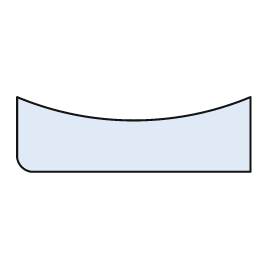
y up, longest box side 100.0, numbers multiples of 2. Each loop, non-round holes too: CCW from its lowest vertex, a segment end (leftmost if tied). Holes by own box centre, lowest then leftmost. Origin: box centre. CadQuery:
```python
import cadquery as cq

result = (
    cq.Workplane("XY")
    .moveTo(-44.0, -16.0)
    .lineTo(50.0, -16.0)
    .lineTo(50.0, 16.0)
    .threePointArc((0.0, 6.0), (-50.0, 16.0))
    .lineTo(-50.0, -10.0)
    .threePointArc((-48.0, -14.0), (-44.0, -16.0))
    .close()
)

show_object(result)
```